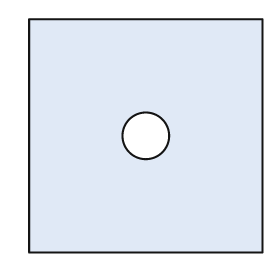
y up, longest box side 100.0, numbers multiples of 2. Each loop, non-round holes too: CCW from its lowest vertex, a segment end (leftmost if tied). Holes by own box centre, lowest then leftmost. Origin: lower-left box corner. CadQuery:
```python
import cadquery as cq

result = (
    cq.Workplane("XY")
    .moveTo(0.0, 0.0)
    .lineTo(100.0, 0.0)
    .lineTo(100.0, 100.0)
    .lineTo(0.0, 100.0)
    .close()
    .moveTo(50.0, 50.0)
    .circle(10.0)
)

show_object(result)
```